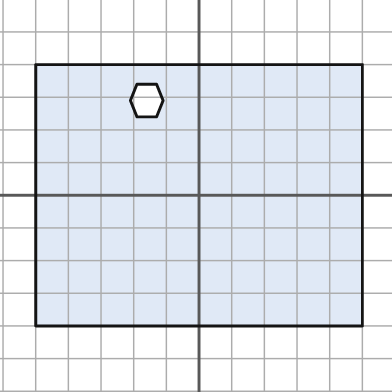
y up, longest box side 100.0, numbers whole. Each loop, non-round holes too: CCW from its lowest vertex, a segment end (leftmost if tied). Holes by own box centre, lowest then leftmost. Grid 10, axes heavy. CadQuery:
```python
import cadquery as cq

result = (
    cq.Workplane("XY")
    .moveTo(-50.0, -40.0)
    .lineTo(50.0, -40.0)
    .lineTo(50.0, 40.0)
    .lineTo(-50.0, 40.0)
    .close()
    .moveTo(-19.0, 24.0)
    .lineTo(-13.0, 24.0)
    .lineTo(-11.0, 29.0)
    .lineTo(-13.0, 34.0)
    .lineTo(-19.0, 34.0)
    .lineTo(-21.0, 29.0)
    .close()
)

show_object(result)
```